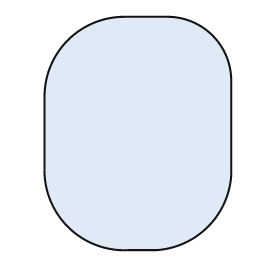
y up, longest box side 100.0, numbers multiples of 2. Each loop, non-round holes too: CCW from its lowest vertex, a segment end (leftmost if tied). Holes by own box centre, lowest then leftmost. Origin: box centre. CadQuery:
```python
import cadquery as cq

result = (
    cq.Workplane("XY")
    .moveTo(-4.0, -50.0)
    .lineTo(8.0, -50.0)
    .threePointArc((30.0, -40.0), (40.0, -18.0))
    .lineTo(40.0, 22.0)
    .threePointArc((32.0, 42.0), (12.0, 50.0))
    .lineTo(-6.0, 50.0)
    .threePointArc((-30.0, 40.0), (-40.0, 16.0))
    .lineTo(-40.0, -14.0)
    .threePointArc((-30.0, -40.0), (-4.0, -50.0))
    .close()
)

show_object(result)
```